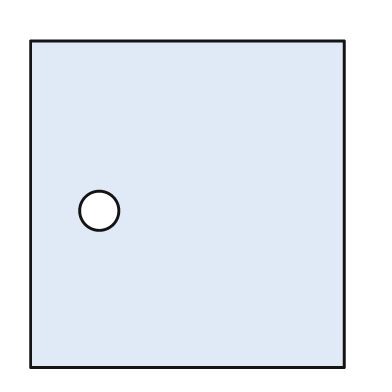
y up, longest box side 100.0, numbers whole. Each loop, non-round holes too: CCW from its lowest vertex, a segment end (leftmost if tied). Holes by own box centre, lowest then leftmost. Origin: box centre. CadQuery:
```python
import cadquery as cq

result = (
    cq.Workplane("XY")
    .moveTo(-48.0, -50.0)
    .lineTo(48.0, -50.0)
    .lineTo(48.0, 50.0)
    .lineTo(-48.0, 50.0)
    .close()
    .moveTo(-27.0, -2.0)
    .circle(6.0)
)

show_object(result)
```